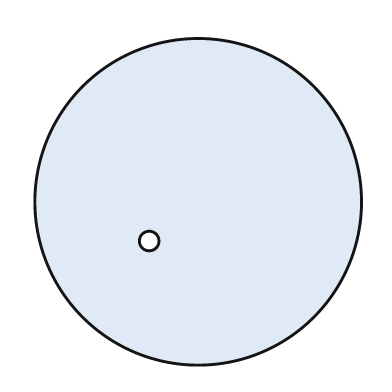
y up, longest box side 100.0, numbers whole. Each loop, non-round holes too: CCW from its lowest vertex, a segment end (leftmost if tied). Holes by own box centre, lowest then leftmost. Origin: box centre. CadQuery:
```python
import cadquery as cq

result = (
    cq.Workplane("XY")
    .moveTo(0.0, 0.0)
    .circle(50.0)
    .moveTo(-15.0, -12.0)
    .circle(3.0)
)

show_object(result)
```